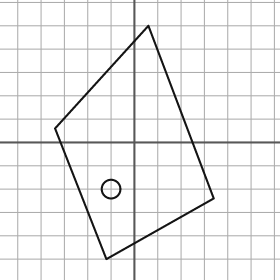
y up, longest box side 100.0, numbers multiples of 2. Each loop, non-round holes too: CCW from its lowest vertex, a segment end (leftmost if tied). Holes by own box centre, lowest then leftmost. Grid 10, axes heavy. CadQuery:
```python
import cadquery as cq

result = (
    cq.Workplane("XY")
    .moveTo(-12.0, -50.0)
    .lineTo(34.0, -24.0)
    .lineTo(6.0, 50.0)
    .lineTo(-34.0, 6.0)
    .close()
    .moveTo(-10.0, -20.0)
    .circle(4.0)
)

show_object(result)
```